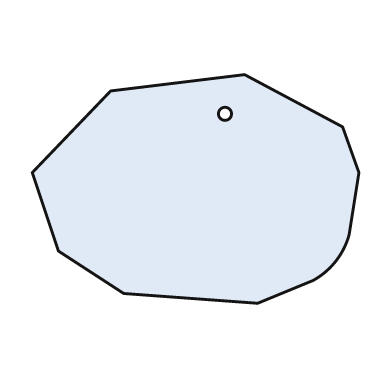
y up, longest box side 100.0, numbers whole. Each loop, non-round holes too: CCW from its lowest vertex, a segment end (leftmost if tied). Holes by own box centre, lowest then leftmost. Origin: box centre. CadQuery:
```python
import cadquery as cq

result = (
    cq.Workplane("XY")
    .moveTo(19.0, -35.0)
    .lineTo(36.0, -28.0)
    .threePointArc((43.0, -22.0), (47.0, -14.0))
    .lineTo(50.0, 5.0)
    .lineTo(45.0, 19.0)
    .lineTo(15.0, 35.0)
    .lineTo(-26.0, 30.0)
    .lineTo(-50.0, 5.0)
    .lineTo(-42.0, -19.0)
    .lineTo(-22.0, -32.0)
    .close()
    .moveTo(9.0, 23.0)
    .circle(2.0)
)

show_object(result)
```